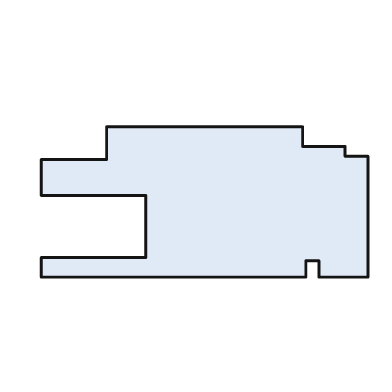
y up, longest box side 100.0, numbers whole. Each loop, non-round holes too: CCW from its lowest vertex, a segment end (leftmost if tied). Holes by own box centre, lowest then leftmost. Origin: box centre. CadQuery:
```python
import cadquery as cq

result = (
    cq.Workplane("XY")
    .moveTo(-50.0, -23.0)
    .lineTo(31.0, -23.0)
    .lineTo(31.0, -18.0)
    .lineTo(35.0, -18.0)
    .lineTo(35.0, -23.0)
    .lineTo(50.0, -23.0)
    .lineTo(50.0, 14.0)
    .lineTo(43.0, 14.0)
    .lineTo(43.0, 17.0)
    .lineTo(30.0, 17.0)
    .lineTo(30.0, 23.0)
    .lineTo(-30.0, 23.0)
    .lineTo(-30.0, 13.0)
    .lineTo(-50.0, 13.0)
    .lineTo(-50.0, 2.0)
    .lineTo(-18.0, 2.0)
    .lineTo(-18.0, -17.0)
    .lineTo(-50.0, -17.0)
    .close()
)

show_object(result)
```